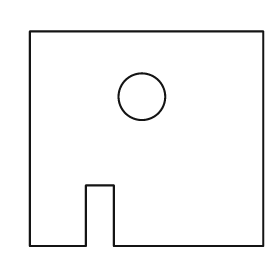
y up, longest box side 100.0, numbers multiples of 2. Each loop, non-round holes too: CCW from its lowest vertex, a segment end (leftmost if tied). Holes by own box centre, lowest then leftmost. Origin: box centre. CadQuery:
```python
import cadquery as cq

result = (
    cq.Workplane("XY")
    .moveTo(-50.0, -46.0)
    .lineTo(-26.0, -46.0)
    .lineTo(-26.0, -20.0)
    .lineTo(-14.0, -20.0)
    .lineTo(-14.0, -46.0)
    .lineTo(50.0, -46.0)
    .lineTo(50.0, 46.0)
    .lineTo(-50.0, 46.0)
    .close()
    .moveTo(-2.0, 18.0)
    .circle(10.0)
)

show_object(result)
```